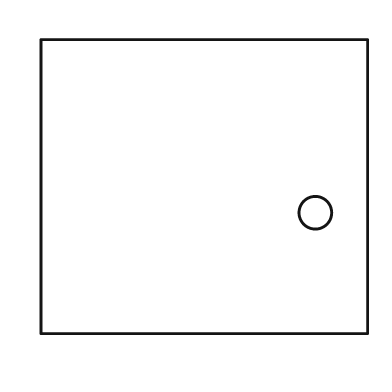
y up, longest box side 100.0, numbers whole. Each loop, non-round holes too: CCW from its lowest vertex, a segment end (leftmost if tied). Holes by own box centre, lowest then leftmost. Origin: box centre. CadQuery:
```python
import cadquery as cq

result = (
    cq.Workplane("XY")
    .moveTo(-50.0, -45.0)
    .lineTo(50.0, -45.0)
    .lineTo(50.0, 45.0)
    .lineTo(-50.0, 45.0)
    .close()
    .moveTo(34.0, -8.0)
    .circle(5.0)
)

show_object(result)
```